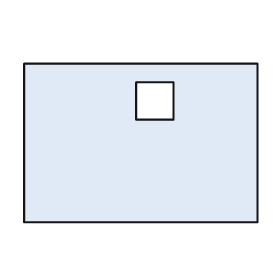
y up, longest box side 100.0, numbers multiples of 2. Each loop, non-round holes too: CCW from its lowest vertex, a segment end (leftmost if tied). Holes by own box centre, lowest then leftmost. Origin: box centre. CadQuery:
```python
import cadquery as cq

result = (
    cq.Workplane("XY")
    .moveTo(-50.0, -34.0)
    .lineTo(50.0, -34.0)
    .lineTo(50.0, 34.0)
    .lineTo(-50.0, 34.0)
    .close()
    .moveTo(-2.0, 10.0)
    .lineTo(14.0, 10.0)
    .lineTo(14.0, 26.0)
    .lineTo(-2.0, 26.0)
    .close()
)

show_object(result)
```